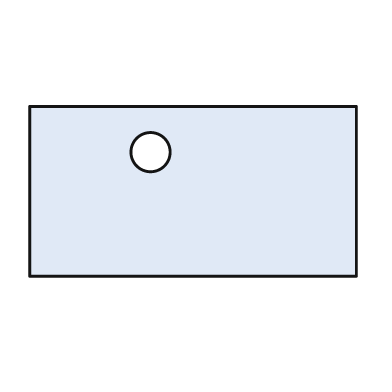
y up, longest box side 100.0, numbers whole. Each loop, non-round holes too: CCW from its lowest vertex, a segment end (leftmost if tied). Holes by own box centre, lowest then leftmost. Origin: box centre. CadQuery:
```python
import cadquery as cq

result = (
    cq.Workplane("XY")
    .moveTo(-50.0, -26.0)
    .lineTo(50.0, -26.0)
    .lineTo(50.0, 26.0)
    .lineTo(-50.0, 26.0)
    .close()
    .moveTo(-13.0, 12.0)
    .circle(6.0)
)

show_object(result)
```